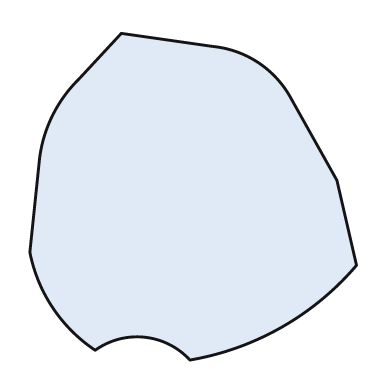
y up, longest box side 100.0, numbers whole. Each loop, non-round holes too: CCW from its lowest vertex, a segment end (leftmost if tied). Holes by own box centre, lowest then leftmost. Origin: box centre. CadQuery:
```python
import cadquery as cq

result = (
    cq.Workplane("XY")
    .moveTo(-1.0, -50.0)
    .threePointArc((27.0, -40.0), (50.0, -21.0))
    .lineTo(44.0, 5.0)
    .lineTo(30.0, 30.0)
    .threePointArc((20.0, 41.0), (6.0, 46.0))
    .lineTo(-22.0, 50.0)
    .lineTo(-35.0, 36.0)
    .threePointArc((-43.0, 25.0), (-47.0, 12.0))
    .lineTo(-50.0, -17.0)
    .threePointArc((-43.0, -34.0), (-30.0, -47.0))
    .threePointArc((-15.0, -43.0), (-1.0, -50.0))
    .close()
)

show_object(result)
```